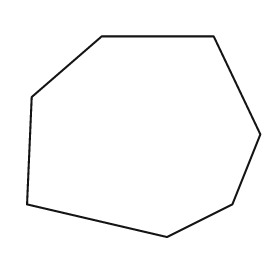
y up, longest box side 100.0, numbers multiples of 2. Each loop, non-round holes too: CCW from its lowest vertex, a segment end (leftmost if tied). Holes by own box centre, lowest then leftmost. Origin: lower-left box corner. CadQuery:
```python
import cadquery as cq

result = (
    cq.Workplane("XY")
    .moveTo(60.0, 0.0)
    .lineTo(88.0, 14.0)
    .lineTo(100.0, 44.0)
    .lineTo(80.0, 86.0)
    .lineTo(32.0, 86.0)
    .lineTo(2.0, 60.0)
    .lineTo(0.0, 14.0)
    .close()
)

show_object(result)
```